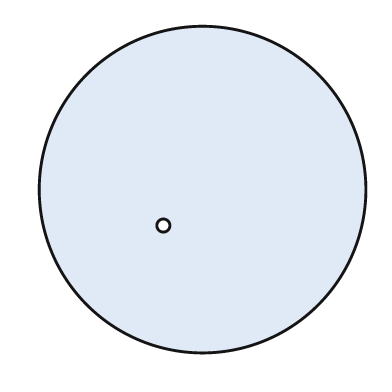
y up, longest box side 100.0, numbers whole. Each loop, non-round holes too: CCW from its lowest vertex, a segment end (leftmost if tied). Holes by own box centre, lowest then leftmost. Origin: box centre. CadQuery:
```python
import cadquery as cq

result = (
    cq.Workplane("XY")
    .moveTo(0.0, 0.0)
    .circle(50.0)
    .moveTo(-12.0, -11.0)
    .circle(2.0)
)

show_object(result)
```